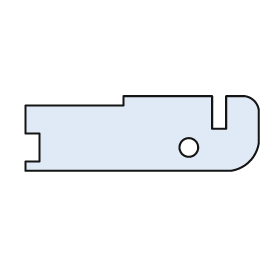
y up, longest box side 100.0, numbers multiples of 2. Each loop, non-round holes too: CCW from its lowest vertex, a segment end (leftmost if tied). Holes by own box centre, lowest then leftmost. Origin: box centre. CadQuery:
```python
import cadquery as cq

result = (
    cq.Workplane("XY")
    .moveTo(-50.0, -16.0)
    .lineTo(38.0, -16.0)
    .threePointArc((46.0, -12.0), (50.0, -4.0))
    .lineTo(50.0, 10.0)
    .threePointArc((48.0, 14.0), (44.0, 16.0))
    .lineTo(36.0, 16.0)
    .lineTo(36.0, 2.0)
    .lineTo(30.0, 2.0)
    .lineTo(30.0, 16.0)
    .lineTo(-8.0, 16.0)
    .lineTo(-8.0, 12.0)
    .lineTo(-50.0, 12.0)
    .lineTo(-50.0, 0.0)
    .lineTo(-44.0, 0.0)
    .lineTo(-44.0, -12.0)
    .lineTo(-50.0, -12.0)
    .close()
    .moveTo(20.0, -6.0)
    .circle(4.0)
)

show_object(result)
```